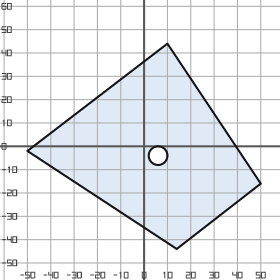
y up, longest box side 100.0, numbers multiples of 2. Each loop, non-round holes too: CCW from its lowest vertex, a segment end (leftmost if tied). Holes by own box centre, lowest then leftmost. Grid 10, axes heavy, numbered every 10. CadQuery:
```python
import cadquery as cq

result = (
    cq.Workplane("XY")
    .moveTo(14.0, -44.0)
    .lineTo(50.0, -16.0)
    .lineTo(10.0, 44.0)
    .lineTo(-50.0, -2.0)
    .close()
    .moveTo(6.0, -4.0)
    .circle(4.0)
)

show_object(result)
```